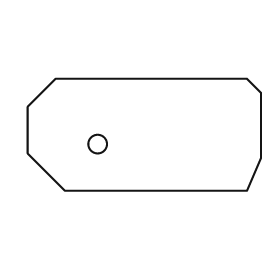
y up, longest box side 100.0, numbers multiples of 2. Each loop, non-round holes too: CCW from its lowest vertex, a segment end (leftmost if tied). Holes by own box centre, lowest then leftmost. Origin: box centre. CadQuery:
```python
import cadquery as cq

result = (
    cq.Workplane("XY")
    .moveTo(-34.0, -24.0)
    .lineTo(44.0, -24.0)
    .lineTo(50.0, -10.0)
    .lineTo(50.0, 18.0)
    .lineTo(44.0, 24.0)
    .lineTo(-38.0, 24.0)
    .lineTo(-50.0, 12.0)
    .lineTo(-50.0, -8.0)
    .close()
    .moveTo(-20.0, -4.0)
    .circle(4.0)
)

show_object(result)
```